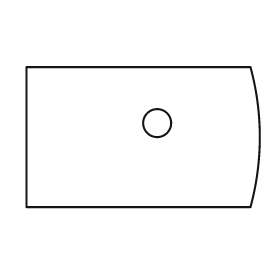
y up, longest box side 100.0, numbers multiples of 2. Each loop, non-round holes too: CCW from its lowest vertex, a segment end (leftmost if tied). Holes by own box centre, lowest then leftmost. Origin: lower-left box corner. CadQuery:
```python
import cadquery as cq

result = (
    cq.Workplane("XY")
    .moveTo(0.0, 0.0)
    .lineTo(96.0, 0.0)
    .threePointArc((100.0, 30.0), (96.0, 60.0))
    .lineTo(0.0, 60.0)
    .close()
    .moveTo(56.0, 36.0)
    .circle(6.0)
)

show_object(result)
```